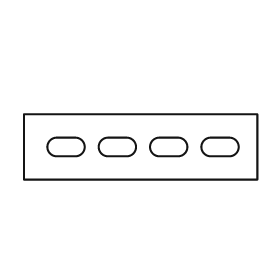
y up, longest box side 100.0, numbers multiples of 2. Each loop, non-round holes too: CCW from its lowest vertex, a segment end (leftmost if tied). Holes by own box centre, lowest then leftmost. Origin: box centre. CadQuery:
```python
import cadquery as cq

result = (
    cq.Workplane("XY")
    .moveTo(-50.0, -14.0)
    .lineTo(50.0, -14.0)
    .lineTo(50.0, 14.0)
    .lineTo(-50.0, 14.0)
    .close()
    .moveTo(-36.0, -4.0)
    .lineTo(-28.0, -4.0)
    .threePointArc((-24.0, 0.0), (-28.0, 4.0))
    .lineTo(-36.0, 4.0)
    .threePointArc((-40.0, 0.0), (-36.0, -4.0))
    .close()
    .moveTo(-14.0, -4.0)
    .lineTo(-6.0, -4.0)
    .threePointArc((-2.0, 0.0), (-6.0, 4.0))
    .lineTo(-14.0, 4.0)
    .threePointArc((-18.0, 0.0), (-14.0, -4.0))
    .close()
    .moveTo(8.0, -4.0)
    .lineTo(16.0, -4.0)
    .threePointArc((20.0, 0.0), (16.0, 4.0))
    .lineTo(8.0, 4.0)
    .threePointArc((4.0, 0.0), (8.0, -4.0))
    .close()
    .moveTo(30.0, -4.0)
    .lineTo(38.0, -4.0)
    .threePointArc((42.0, 0.0), (38.0, 4.0))
    .lineTo(30.0, 4.0)
    .threePointArc((26.0, 0.0), (30.0, -4.0))
    .close()
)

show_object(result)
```